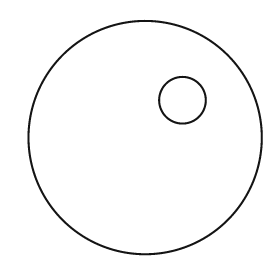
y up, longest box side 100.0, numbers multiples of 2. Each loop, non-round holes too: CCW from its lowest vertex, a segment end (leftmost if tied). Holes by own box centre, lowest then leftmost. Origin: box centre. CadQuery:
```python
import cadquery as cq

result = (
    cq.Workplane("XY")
    .moveTo(0.0, 0.0)
    .circle(50.0)
    .moveTo(16.0, 16.0)
    .circle(10.0)
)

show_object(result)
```